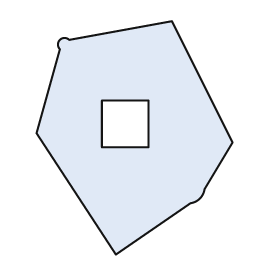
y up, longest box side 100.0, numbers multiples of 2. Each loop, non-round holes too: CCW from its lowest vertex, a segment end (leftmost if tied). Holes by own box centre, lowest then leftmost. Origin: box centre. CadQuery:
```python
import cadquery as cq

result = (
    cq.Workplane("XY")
    .moveTo(-8.0, -50.0)
    .lineTo(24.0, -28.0)
    .threePointArc((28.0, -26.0), (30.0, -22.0))
    .lineTo(42.0, -2.0)
    .lineTo(16.0, 50.0)
    .lineTo(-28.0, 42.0)
    .threePointArc((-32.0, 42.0), (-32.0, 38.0))
    .lineTo(-42.0, 2.0)
    .close()
    .moveTo(-14.0, -4.0)
    .lineTo(6.0, -4.0)
    .lineTo(6.0, 16.0)
    .lineTo(-14.0, 16.0)
    .close()
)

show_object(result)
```